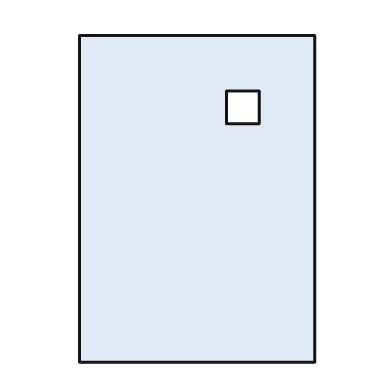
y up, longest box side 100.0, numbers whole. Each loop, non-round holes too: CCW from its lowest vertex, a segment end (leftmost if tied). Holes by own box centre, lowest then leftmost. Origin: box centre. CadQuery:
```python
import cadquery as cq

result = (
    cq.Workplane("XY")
    .moveTo(-36.0, -50.0)
    .lineTo(36.0, -50.0)
    .lineTo(36.0, 50.0)
    .lineTo(-36.0, 50.0)
    .close()
    .moveTo(9.0, 23.0)
    .lineTo(19.0, 23.0)
    .lineTo(19.0, 33.0)
    .lineTo(9.0, 33.0)
    .close()
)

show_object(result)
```